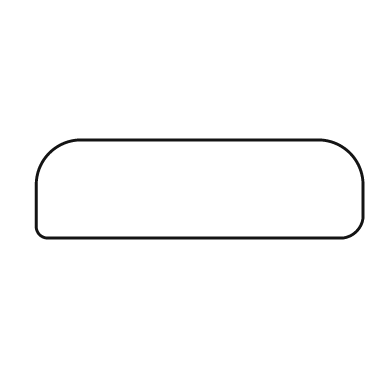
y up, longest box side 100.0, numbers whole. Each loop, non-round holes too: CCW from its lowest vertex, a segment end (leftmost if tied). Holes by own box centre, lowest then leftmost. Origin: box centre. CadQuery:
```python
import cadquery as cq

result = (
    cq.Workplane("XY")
    .moveTo(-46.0, -15.0)
    .lineTo(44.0, -15.0)
    .threePointArc((48.0, -13.0), (50.0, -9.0))
    .lineTo(50.0, 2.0)
    .threePointArc((46.0, 11.0), (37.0, 15.0))
    .lineTo(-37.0, 15.0)
    .threePointArc((-46.0, 11.0), (-50.0, 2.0))
    .lineTo(-50.0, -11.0)
    .threePointArc((-49.0, -14.0), (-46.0, -15.0))
    .close()
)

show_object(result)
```